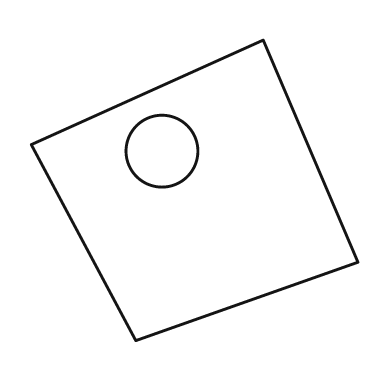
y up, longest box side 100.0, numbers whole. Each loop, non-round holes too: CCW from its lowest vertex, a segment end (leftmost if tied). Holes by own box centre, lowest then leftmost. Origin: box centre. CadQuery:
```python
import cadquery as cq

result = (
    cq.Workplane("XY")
    .moveTo(-18.0, -46.0)
    .lineTo(50.0, -22.0)
    .lineTo(21.0, 46.0)
    .lineTo(-50.0, 14.0)
    .close()
    .moveTo(-10.0, 12.0)
    .circle(11.0)
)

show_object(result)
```